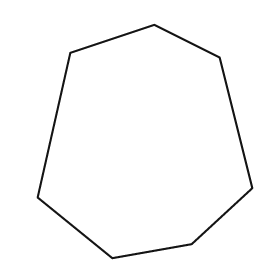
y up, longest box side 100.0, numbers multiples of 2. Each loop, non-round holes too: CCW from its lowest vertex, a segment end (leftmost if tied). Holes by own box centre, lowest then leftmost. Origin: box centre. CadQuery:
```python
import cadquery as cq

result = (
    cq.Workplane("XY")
    .moveTo(-14.0, -50.0)
    .lineTo(20.0, -44.0)
    .lineTo(46.0, -20.0)
    .lineTo(32.0, 36.0)
    .lineTo(4.0, 50.0)
    .lineTo(-32.0, 38.0)
    .lineTo(-46.0, -24.0)
    .close()
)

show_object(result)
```